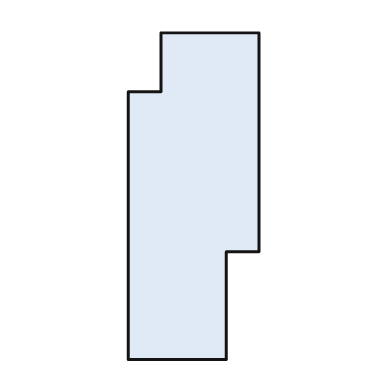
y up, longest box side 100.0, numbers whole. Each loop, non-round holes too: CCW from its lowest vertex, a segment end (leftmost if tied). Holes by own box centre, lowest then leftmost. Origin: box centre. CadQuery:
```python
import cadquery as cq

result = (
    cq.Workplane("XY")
    .moveTo(-20.0, -50.0)
    .lineTo(10.0, -50.0)
    .lineTo(10.0, -17.0)
    .lineTo(20.0, -17.0)
    .lineTo(20.0, 50.0)
    .lineTo(-10.0, 50.0)
    .lineTo(-10.0, 32.0)
    .lineTo(-20.0, 32.0)
    .close()
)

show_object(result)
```